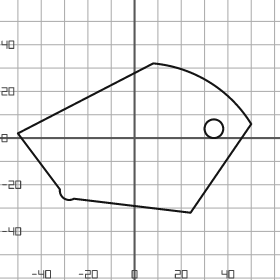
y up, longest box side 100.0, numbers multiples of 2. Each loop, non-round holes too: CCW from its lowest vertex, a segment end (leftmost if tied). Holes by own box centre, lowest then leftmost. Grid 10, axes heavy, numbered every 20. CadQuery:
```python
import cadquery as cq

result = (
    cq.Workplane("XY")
    .moveTo(24.0, -32.0)
    .lineTo(50.0, 6.0)
    .threePointArc((32.0, 24.0), (8.0, 32.0))
    .lineTo(-50.0, 2.0)
    .lineTo(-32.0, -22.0)
    .threePointArc((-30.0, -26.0), (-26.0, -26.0))
    .close()
    .moveTo(34.0, 4.0)
    .circle(4.0)
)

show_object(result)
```